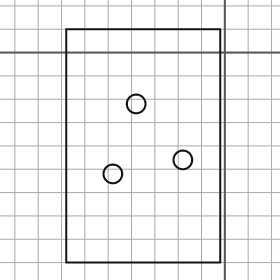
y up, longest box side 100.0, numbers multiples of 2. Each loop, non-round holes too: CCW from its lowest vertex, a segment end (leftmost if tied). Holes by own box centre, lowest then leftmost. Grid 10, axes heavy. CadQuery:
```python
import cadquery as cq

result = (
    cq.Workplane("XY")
    .moveTo(-68.0, -90.0)
    .lineTo(-2.0, -90.0)
    .lineTo(-2.0, 10.0)
    .lineTo(-68.0, 10.0)
    .close()
    .moveTo(-48.0, -52.0)
    .circle(4.0)
    .moveTo(-18.0, -46.0)
    .circle(4.0)
    .moveTo(-38.0, -22.0)
    .circle(4.0)
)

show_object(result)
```